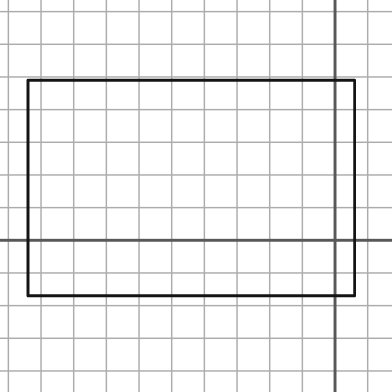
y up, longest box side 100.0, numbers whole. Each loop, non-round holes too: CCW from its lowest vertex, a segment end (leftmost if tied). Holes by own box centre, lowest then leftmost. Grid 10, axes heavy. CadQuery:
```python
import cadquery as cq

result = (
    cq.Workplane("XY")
    .moveTo(-94.0, -17.0)
    .lineTo(6.0, -17.0)
    .lineTo(6.0, 49.0)
    .lineTo(-94.0, 49.0)
    .close()
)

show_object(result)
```